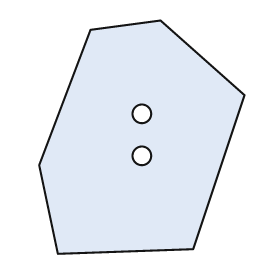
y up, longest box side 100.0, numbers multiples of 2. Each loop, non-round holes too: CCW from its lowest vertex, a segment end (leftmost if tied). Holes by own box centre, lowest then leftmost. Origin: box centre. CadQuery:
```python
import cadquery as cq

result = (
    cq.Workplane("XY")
    .moveTo(-36.0, -50.0)
    .lineTo(22.0, -48.0)
    .lineTo(44.0, 18.0)
    .lineTo(8.0, 50.0)
    .lineTo(-22.0, 46.0)
    .lineTo(-44.0, -12.0)
    .close()
    .moveTo(0.0, -8.0)
    .circle(4.0)
    .moveTo(0.0, 10.0)
    .circle(4.0)
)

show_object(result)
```